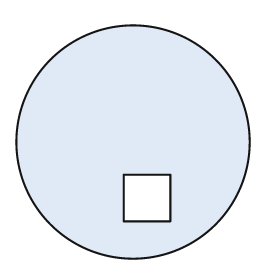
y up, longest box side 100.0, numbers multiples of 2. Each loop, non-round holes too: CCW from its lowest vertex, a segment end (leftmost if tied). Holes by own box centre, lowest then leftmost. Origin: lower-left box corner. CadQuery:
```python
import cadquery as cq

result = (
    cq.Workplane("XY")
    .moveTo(50.0, 50.0)
    .circle(50.0)
    .moveTo(46.0, 16.0)
    .lineTo(66.0, 16.0)
    .lineTo(66.0, 36.0)
    .lineTo(46.0, 36.0)
    .close()
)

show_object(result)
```